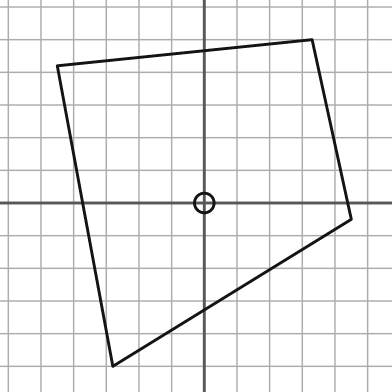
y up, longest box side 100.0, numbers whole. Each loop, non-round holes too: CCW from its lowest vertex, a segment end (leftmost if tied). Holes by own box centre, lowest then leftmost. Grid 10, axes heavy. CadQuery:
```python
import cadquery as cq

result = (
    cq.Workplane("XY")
    .moveTo(-28.0, -50.0)
    .lineTo(45.0, -5.0)
    .lineTo(33.0, 50.0)
    .lineTo(-45.0, 42.0)
    .close()
    .moveTo(0.0, 0.0)
    .circle(3.0)
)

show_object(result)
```